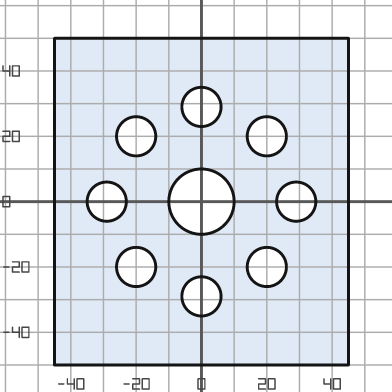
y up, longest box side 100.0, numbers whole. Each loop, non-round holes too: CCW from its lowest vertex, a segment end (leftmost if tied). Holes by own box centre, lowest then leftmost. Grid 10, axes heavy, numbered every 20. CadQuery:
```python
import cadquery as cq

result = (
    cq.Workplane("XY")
    .moveTo(-45.0, -50.0)
    .lineTo(45.0, -50.0)
    .lineTo(45.0, 50.0)
    .lineTo(-45.0, 50.0)
    .close()
    .moveTo(0.0, -29.0)
    .circle(6.0)
    .moveTo(-20.0, -20.0)
    .circle(6.0)
    .moveTo(20.0, -20.0)
    .circle(6.0)
    .moveTo(-29.0, 0.0)
    .circle(6.0)
    .moveTo(0.0, 0.0)
    .circle(10.0)
    .moveTo(29.0, 0.0)
    .circle(6.0)
    .moveTo(-20.0, 20.0)
    .circle(6.0)
    .moveTo(20.0, 20.0)
    .circle(6.0)
    .moveTo(0.0, 29.0)
    .circle(6.0)
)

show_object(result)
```